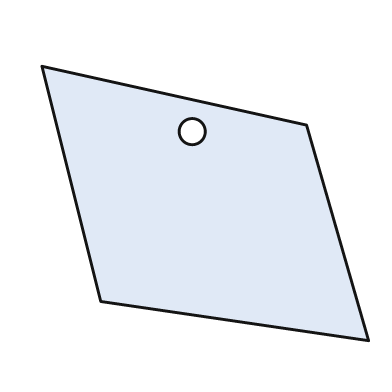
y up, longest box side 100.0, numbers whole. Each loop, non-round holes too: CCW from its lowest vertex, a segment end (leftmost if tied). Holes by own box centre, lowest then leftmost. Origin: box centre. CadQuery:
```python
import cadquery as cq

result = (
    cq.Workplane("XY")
    .moveTo(50.0, -42.0)
    .lineTo(31.0, 24.0)
    .lineTo(-50.0, 42.0)
    .lineTo(-32.0, -30.0)
    .close()
    .moveTo(-4.0, 22.0)
    .circle(4.0)
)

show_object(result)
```